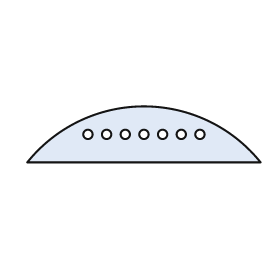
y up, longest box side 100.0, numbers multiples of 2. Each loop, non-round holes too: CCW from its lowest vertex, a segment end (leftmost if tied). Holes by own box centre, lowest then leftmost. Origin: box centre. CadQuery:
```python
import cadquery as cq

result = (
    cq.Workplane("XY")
    .moveTo(-50.0, -12.0)
    .lineTo(50.0, -12.0)
    .threePointArc((0.0, 12.0), (-50.0, -12.0))
    .close()
    .moveTo(-24.0, 0.0)
    .circle(2.0)
    .moveTo(-16.0, 0.0)
    .circle(2.0)
    .moveTo(-8.0, 0.0)
    .circle(2.0)
    .moveTo(0.0, 0.0)
    .circle(2.0)
    .moveTo(8.0, 0.0)
    .circle(2.0)
    .moveTo(16.0, 0.0)
    .circle(2.0)
    .moveTo(24.0, 0.0)
    .circle(2.0)
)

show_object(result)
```